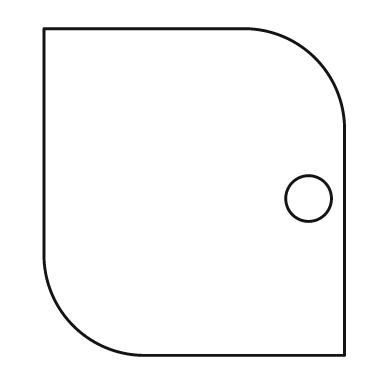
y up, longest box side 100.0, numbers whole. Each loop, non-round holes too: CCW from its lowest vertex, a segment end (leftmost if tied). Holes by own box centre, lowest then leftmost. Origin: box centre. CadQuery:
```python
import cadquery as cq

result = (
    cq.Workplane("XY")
    .moveTo(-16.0, -50.0)
    .lineTo(46.0, -50.0)
    .lineTo(46.0, 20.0)
    .threePointArc((37.0, 41.0), (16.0, 50.0))
    .lineTo(-46.0, 50.0)
    .lineTo(-46.0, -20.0)
    .threePointArc((-37.0, -41.0), (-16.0, -50.0))
    .close()
    .moveTo(35.0, -2.0)
    .circle(7.0)
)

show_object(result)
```